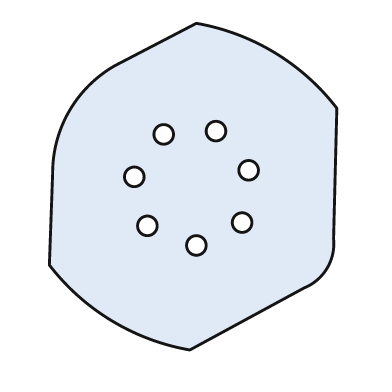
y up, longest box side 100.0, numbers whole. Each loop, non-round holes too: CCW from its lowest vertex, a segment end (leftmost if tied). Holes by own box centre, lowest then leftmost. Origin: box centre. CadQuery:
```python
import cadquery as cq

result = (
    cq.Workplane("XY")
    .moveTo(-1.0, -50.0)
    .lineTo(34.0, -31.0)
    .threePointArc((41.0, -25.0), (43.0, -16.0))
    .lineTo(44.0, 24.0)
    .threePointArc((25.0, 41.0), (1.0, 50.0))
    .lineTo(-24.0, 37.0)
    .threePointArc((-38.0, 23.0), (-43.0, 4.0))
    .lineTo(-44.0, -24.0)
    .threePointArc((-25.0, -41.0), (-1.0, -50.0))
    .close()
    .moveTo(1.0, -18.0)
    .circle(3.0)
    .moveTo(-14.0, -12.0)
    .circle(3.0)
    .moveTo(15.0, -11.0)
    .circle(3.0)
    .moveTo(-18.0, 3.0)
    .circle(3.0)
    .moveTo(17.0, 5.0)
    .circle(3.0)
    .moveTo(-9.0, 16.0)
    .circle(3.0)
    .moveTo(7.0, 17.0)
    .circle(3.0)
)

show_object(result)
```